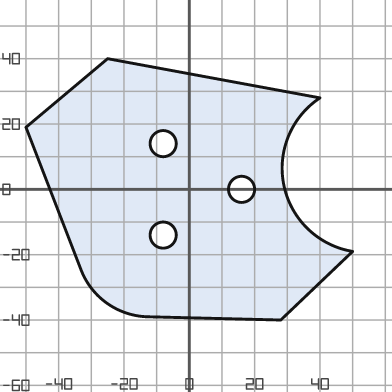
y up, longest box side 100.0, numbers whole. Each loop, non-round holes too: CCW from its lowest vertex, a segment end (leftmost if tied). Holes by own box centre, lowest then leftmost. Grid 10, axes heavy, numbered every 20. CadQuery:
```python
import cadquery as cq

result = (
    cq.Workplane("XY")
    .moveTo(28.0, -40.0)
    .lineTo(50.0, -19.0)
    .threePointArc((29.0, 1.0), (40.0, 28.0))
    .lineTo(-25.0, 40.0)
    .lineTo(-50.0, 19.0)
    .lineTo(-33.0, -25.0)
    .threePointArc((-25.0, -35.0), (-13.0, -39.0))
    .close()
    .moveTo(-8.0, -14.0)
    .circle(4.0)
    .moveTo(16.0, 0.0)
    .circle(4.0)
    .moveTo(-8.0, 14.0)
    .circle(4.0)
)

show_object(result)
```